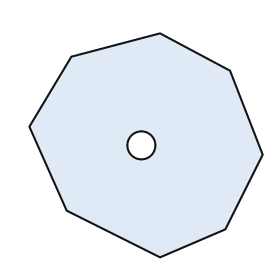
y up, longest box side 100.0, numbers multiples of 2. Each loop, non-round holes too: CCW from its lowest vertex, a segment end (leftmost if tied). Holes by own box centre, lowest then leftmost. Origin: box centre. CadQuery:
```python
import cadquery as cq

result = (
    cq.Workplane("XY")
    .moveTo(6.0, -48.0)
    .lineTo(34.0, -36.0)
    .lineTo(50.0, -4.0)
    .lineTo(36.0, 32.0)
    .lineTo(6.0, 48.0)
    .lineTo(-32.0, 38.0)
    .lineTo(-50.0, 8.0)
    .lineTo(-34.0, -28.0)
    .close()
    .moveTo(-2.0, 0.0)
    .circle(6.0)
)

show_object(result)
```